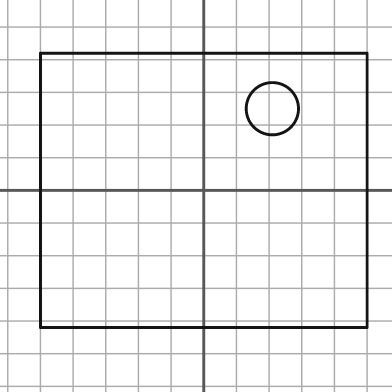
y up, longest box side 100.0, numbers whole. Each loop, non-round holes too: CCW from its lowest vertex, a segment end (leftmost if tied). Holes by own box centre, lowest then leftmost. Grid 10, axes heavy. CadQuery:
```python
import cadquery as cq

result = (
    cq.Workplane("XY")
    .moveTo(-50.0, -42.0)
    .lineTo(50.0, -42.0)
    .lineTo(50.0, 42.0)
    .lineTo(-50.0, 42.0)
    .close()
    .moveTo(21.0, 25.0)
    .circle(8.0)
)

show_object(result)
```